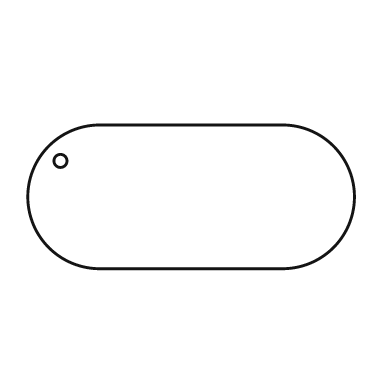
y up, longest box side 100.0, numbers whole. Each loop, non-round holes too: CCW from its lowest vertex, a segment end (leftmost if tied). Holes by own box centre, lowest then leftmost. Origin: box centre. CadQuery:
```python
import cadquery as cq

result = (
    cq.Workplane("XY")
    .moveTo(-28.0, -22.0)
    .lineTo(28.0, -22.0)
    .threePointArc((50.0, 0.0), (28.0, 22.0))
    .lineTo(-28.0, 22.0)
    .threePointArc((-50.0, 0.0), (-28.0, -22.0))
    .close()
    .moveTo(-40.0, 11.0)
    .circle(2.0)
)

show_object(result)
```